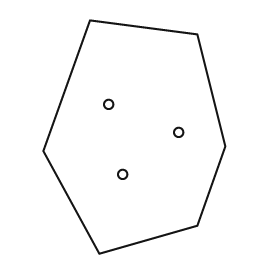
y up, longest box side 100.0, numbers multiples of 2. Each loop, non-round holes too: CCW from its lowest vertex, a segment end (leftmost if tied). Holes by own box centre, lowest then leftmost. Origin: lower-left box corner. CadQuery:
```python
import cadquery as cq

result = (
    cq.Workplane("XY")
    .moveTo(24.0, 0.0)
    .lineTo(66.0, 12.0)
    .lineTo(78.0, 46.0)
    .lineTo(66.0, 94.0)
    .lineTo(20.0, 100.0)
    .lineTo(0.0, 44.0)
    .close()
    .moveTo(34.0, 34.0)
    .circle(2.0)
    .moveTo(58.0, 52.0)
    .circle(2.0)
    .moveTo(28.0, 64.0)
    .circle(2.0)
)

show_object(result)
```